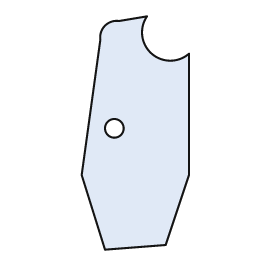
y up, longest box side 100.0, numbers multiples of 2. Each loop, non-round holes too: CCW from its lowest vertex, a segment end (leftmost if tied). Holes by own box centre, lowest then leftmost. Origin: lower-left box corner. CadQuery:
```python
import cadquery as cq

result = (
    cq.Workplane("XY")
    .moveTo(10.0, 0.0)
    .lineTo(36.0, 2.0)
    .lineTo(46.0, 32.0)
    .lineTo(46.0, 84.0)
    .threePointArc((30.0, 84.0), (28.0, 100.0))
    .lineTo(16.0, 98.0)
    .threePointArc((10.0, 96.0), (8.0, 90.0))
    .lineTo(0.0, 32.0)
    .close()
    .moveTo(14.0, 52.0)
    .circle(4.0)
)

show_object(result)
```